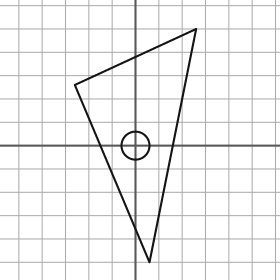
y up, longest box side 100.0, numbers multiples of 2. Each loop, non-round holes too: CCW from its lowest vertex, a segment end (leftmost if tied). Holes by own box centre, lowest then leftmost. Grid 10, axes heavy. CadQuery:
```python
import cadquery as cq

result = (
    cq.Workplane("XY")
    .moveTo(6.0, -50.0)
    .lineTo(26.0, 50.0)
    .lineTo(-26.0, 26.0)
    .close()
    .moveTo(0.0, 0.0)
    .circle(6.0)
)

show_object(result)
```